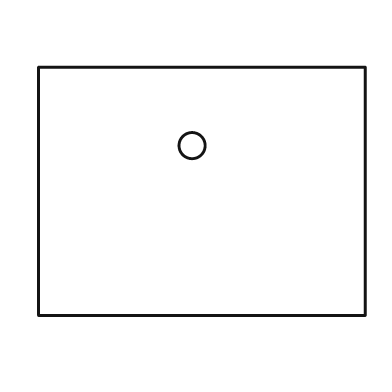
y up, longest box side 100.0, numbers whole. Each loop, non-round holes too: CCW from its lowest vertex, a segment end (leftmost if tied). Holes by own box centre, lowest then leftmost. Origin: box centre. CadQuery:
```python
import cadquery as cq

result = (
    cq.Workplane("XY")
    .moveTo(-50.0, -38.0)
    .lineTo(50.0, -38.0)
    .lineTo(50.0, 38.0)
    .lineTo(-50.0, 38.0)
    .close()
    .moveTo(-3.0, 14.0)
    .circle(4.0)
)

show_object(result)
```